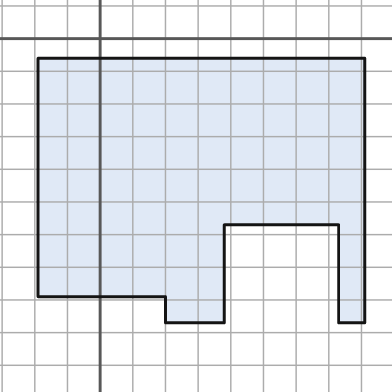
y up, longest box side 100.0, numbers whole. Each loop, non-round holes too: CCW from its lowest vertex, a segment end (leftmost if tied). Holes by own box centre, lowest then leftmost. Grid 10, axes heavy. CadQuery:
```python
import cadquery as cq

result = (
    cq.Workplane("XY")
    .moveTo(20.0, -87.0)
    .lineTo(38.0, -87.0)
    .lineTo(38.0, -57.0)
    .lineTo(73.0, -57.0)
    .lineTo(73.0, -87.0)
    .lineTo(81.0, -87.0)
    .lineTo(81.0, -6.0)
    .lineTo(-19.0, -6.0)
    .lineTo(-19.0, -79.0)
    .lineTo(20.0, -79.0)
    .close()
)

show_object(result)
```